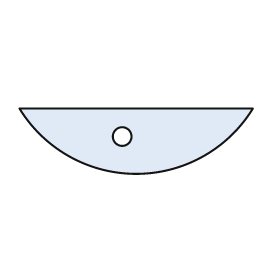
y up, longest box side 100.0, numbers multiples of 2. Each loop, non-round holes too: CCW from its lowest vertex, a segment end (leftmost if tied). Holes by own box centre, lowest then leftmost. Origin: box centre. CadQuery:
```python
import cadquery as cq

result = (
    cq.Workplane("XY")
    .moveTo(-50.0, 14.0)
    .threePointArc((0.0, -14.0), (50.0, 14.0))
    .close()
    .moveTo(-6.0, 2.0)
    .circle(4.0)
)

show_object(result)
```